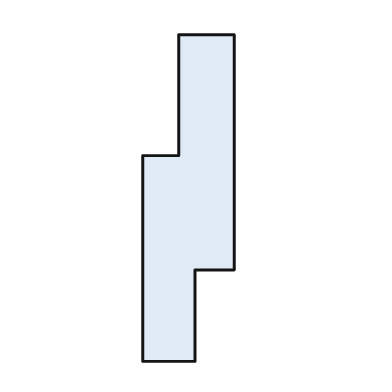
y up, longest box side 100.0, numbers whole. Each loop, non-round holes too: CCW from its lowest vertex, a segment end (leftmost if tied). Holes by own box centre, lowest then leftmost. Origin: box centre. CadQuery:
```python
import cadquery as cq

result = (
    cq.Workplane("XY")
    .moveTo(-14.0, -50.0)
    .lineTo(2.0, -50.0)
    .lineTo(2.0, -22.0)
    .lineTo(14.0, -22.0)
    .lineTo(14.0, 50.0)
    .lineTo(-3.0, 50.0)
    .lineTo(-3.0, 13.0)
    .lineTo(-14.0, 13.0)
    .close()
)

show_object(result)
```